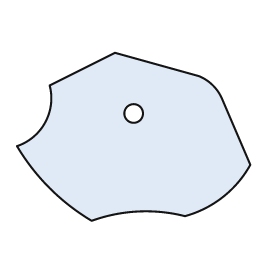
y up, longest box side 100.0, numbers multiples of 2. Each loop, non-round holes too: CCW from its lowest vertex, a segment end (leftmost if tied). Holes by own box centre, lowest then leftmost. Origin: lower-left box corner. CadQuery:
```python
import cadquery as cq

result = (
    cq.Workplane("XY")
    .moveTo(32.0, 0.0)
    .threePointArc((52.0, 4.0), (72.0, 2.0))
    .threePointArc((88.0, 10.0), (100.0, 24.0))
    .lineTo(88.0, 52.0)
    .threePointArc((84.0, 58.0), (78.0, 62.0))
    .lineTo(42.0, 72.0)
    .lineTo(14.0, 58.0)
    .threePointArc((12.0, 42.0), (0.0, 32.0))
    .threePointArc((14.0, 14.0), (32.0, 0.0))
    .close()
    .moveTo(50.0, 46.0)
    .circle(4.0)
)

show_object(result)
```